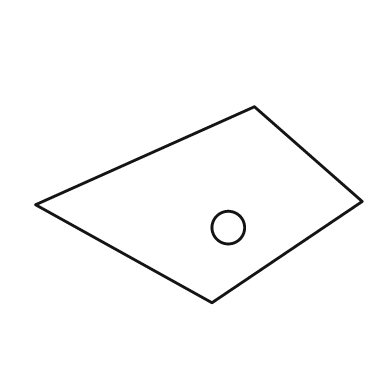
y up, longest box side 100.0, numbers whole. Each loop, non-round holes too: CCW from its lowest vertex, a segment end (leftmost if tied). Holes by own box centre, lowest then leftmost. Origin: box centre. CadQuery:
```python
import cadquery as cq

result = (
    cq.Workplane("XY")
    .moveTo(4.0, -30.0)
    .lineTo(50.0, 1.0)
    .lineTo(17.0, 30.0)
    .lineTo(-50.0, 0.0)
    .close()
    .moveTo(9.0, -7.0)
    .circle(5.0)
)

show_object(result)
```